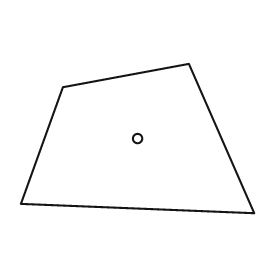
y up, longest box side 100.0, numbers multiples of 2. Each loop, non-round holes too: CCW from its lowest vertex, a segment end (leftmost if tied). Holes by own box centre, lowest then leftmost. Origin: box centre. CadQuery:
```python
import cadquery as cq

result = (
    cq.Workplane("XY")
    .moveTo(50.0, -32.0)
    .lineTo(22.0, 32.0)
    .lineTo(-32.0, 22.0)
    .lineTo(-50.0, -28.0)
    .close()
    .moveTo(0.0, 0.0)
    .circle(2.0)
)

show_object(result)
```